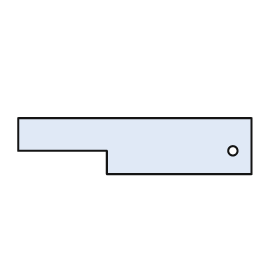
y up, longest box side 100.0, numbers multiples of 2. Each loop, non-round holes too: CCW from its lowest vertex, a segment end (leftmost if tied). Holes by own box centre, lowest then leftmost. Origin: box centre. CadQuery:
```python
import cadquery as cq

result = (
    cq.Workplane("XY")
    .moveTo(-12.0, -12.0)
    .lineTo(50.0, -12.0)
    .lineTo(50.0, 12.0)
    .lineTo(-50.0, 12.0)
    .lineTo(-50.0, -2.0)
    .lineTo(-12.0, -2.0)
    .close()
    .moveTo(42.0, -2.0)
    .circle(2.0)
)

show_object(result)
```